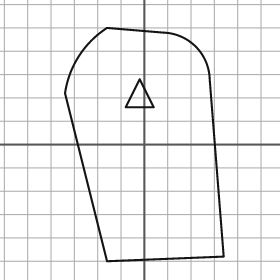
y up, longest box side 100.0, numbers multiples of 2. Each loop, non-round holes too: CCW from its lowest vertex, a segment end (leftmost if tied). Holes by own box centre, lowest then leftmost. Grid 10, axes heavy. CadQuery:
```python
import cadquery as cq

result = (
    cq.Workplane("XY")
    .moveTo(-16.0, -50.0)
    .lineTo(34.0, -48.0)
    .lineTo(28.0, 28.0)
    .threePointArc((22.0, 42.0), (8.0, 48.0))
    .lineTo(-16.0, 50.0)
    .threePointArc((-28.0, 38.0), (-34.0, 22.0))
    .close()
    .moveTo(-8.0, 16.0)
    .lineTo(4.0, 16.0)
    .lineTo(-2.0, 28.0)
    .close()
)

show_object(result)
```